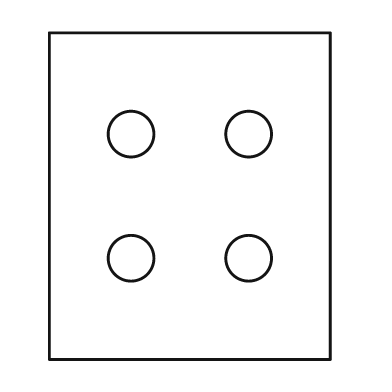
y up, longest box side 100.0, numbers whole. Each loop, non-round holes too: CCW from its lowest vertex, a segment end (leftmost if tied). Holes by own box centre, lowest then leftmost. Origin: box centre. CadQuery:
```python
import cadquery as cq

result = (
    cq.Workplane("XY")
    .moveTo(-43.0, -50.0)
    .lineTo(43.0, -50.0)
    .lineTo(43.0, 50.0)
    .lineTo(-43.0, 50.0)
    .close()
    .moveTo(-18.0, -19.0)
    .circle(7.0)
    .moveTo(18.0, -19.0)
    .circle(7.0)
    .moveTo(-18.0, 19.0)
    .circle(7.0)
    .moveTo(18.0, 19.0)
    .circle(7.0)
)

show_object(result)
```